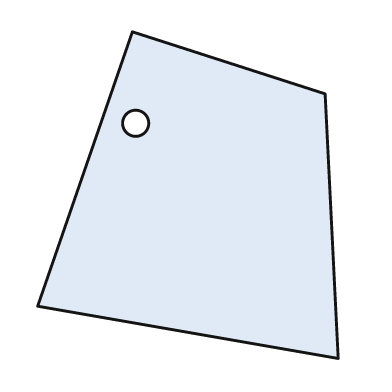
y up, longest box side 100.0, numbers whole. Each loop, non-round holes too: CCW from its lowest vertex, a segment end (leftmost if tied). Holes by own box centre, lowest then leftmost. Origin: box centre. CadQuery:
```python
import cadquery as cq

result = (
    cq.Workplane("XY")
    .moveTo(46.0, -50.0)
    .lineTo(42.0, 31.0)
    .lineTo(-17.0, 50.0)
    .lineTo(-46.0, -34.0)
    .close()
    .moveTo(-16.0, 22.0)
    .circle(4.0)
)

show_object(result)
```